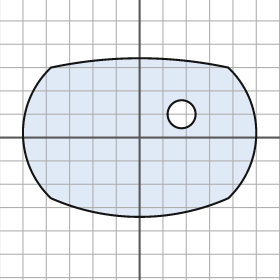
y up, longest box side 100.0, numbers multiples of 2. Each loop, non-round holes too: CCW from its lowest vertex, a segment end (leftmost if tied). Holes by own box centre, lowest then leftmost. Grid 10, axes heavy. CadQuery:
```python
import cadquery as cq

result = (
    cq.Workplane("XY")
    .moveTo(-38.0, -26.0)
    .threePointArc((0.0, -34.0), (38.0, -26.0))
    .threePointArc((50.0, 2.0), (38.0, 30.0))
    .threePointArc((0.0, 34.0), (-38.0, 30.0))
    .threePointArc((-50.0, 2.0), (-38.0, -26.0))
    .close()
    .moveTo(18.0, 10.0)
    .circle(6.0)
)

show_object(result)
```